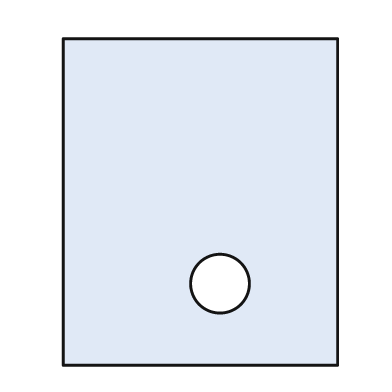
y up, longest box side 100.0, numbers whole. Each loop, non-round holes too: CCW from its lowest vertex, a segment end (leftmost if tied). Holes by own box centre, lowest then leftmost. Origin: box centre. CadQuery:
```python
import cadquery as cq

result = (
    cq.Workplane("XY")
    .moveTo(-42.0, -50.0)
    .lineTo(42.0, -50.0)
    .lineTo(42.0, 50.0)
    .lineTo(-42.0, 50.0)
    .close()
    .moveTo(6.0, -25.0)
    .circle(9.0)
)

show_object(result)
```